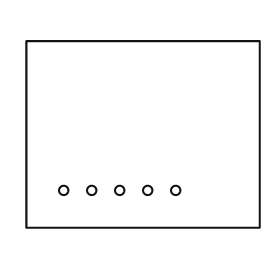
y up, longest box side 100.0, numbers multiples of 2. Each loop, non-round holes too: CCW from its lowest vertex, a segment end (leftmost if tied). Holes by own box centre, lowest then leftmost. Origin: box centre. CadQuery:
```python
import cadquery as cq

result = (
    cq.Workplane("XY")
    .moveTo(-50.0, -40.0)
    .lineTo(50.0, -40.0)
    .lineTo(50.0, 40.0)
    .lineTo(-50.0, 40.0)
    .close()
    .moveTo(-34.0, -24.0)
    .circle(2.0)
    .moveTo(-22.0, -24.0)
    .circle(2.0)
    .moveTo(-10.0, -24.0)
    .circle(2.0)
    .moveTo(2.0, -24.0)
    .circle(2.0)
    .moveTo(14.0, -24.0)
    .circle(2.0)
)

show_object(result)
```